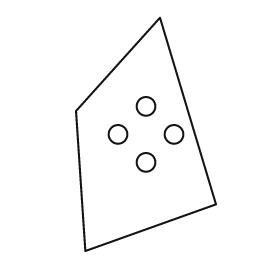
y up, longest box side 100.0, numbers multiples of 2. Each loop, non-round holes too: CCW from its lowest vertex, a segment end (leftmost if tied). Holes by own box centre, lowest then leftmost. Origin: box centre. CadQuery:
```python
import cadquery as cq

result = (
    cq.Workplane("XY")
    .moveTo(-26.0, -50.0)
    .lineTo(30.0, -30.0)
    .lineTo(6.0, 50.0)
    .lineTo(-30.0, 10.0)
    .close()
    .moveTo(0.0, -12.0)
    .circle(4.0)
    .moveTo(-12.0, 0.0)
    .circle(4.0)
    .moveTo(12.0, 0.0)
    .circle(4.0)
    .moveTo(0.0, 12.0)
    .circle(4.0)
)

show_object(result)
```